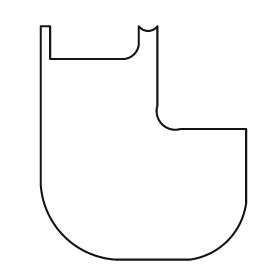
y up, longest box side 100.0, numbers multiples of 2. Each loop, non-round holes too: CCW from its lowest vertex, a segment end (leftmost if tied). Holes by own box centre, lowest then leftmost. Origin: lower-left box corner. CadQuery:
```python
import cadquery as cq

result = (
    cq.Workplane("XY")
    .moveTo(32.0, 0.0)
    .lineTo(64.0, 0.0)
    .threePointArc((80.0, 8.0), (88.0, 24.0))
    .lineTo(88.0, 56.0)
    .lineTo(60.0, 56.0)
    .threePointArc((52.0, 58.0), (50.0, 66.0))
    .lineTo(50.0, 100.0)
    .threePointArc((46.0, 98.0), (42.0, 100.0))
    .lineTo(42.0, 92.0)
    .threePointArc((40.0, 88.0), (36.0, 86.0))
    .lineTo(4.0, 86.0)
    .lineTo(4.0, 100.0)
    .lineTo(0.0, 100.0)
    .lineTo(0.0, 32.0)
    .threePointArc((10.0, 10.0), (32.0, 0.0))
    .close()
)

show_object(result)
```